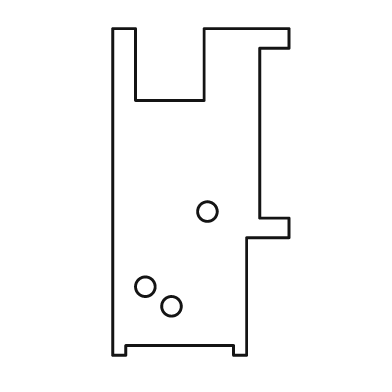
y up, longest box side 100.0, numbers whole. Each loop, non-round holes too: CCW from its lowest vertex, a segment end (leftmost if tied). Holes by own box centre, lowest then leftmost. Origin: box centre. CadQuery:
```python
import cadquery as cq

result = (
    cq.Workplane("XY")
    .moveTo(-27.0, -50.0)
    .lineTo(-23.0, -50.0)
    .lineTo(-23.0, -47.0)
    .lineTo(10.0, -47.0)
    .lineTo(10.0, -50.0)
    .lineTo(14.0, -50.0)
    .lineTo(14.0, -14.0)
    .lineTo(27.0, -14.0)
    .lineTo(27.0, -8.0)
    .lineTo(18.0, -8.0)
    .lineTo(18.0, 44.0)
    .lineTo(27.0, 44.0)
    .lineTo(27.0, 50.0)
    .lineTo(1.0, 50.0)
    .lineTo(1.0, 28.0)
    .lineTo(-20.0, 28.0)
    .lineTo(-20.0, 50.0)
    .lineTo(-27.0, 50.0)
    .close()
    .moveTo(-9.0, -35.0)
    .circle(3.0)
    .moveTo(-17.0, -29.0)
    .circle(3.0)
    .moveTo(2.0, -6.0)
    .circle(3.0)
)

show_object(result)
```